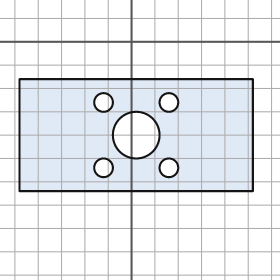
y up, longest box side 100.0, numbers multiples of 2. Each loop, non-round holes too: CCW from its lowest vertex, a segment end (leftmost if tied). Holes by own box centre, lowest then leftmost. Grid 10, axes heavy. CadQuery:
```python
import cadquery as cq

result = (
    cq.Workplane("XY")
    .moveTo(-48.0, -64.0)
    .lineTo(52.0, -64.0)
    .lineTo(52.0, -16.0)
    .lineTo(-48.0, -16.0)
    .close()
    .moveTo(-12.0, -54.0)
    .circle(4.0)
    .moveTo(16.0, -54.0)
    .circle(4.0)
    .moveTo(2.0, -40.0)
    .circle(10.0)
    .moveTo(-12.0, -26.0)
    .circle(4.0)
    .moveTo(16.0, -26.0)
    .circle(4.0)
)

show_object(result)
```